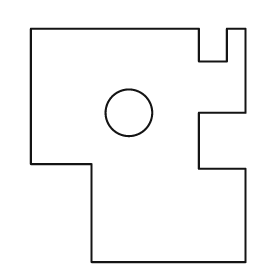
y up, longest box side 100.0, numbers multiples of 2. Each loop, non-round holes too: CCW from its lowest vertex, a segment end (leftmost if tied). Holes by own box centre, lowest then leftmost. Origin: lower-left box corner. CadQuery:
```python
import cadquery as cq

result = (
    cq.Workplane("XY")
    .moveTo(26.0, 0.0)
    .lineTo(92.0, 0.0)
    .lineTo(92.0, 40.0)
    .lineTo(72.0, 40.0)
    .lineTo(72.0, 64.0)
    .lineTo(92.0, 64.0)
    .lineTo(92.0, 100.0)
    .lineTo(84.0, 100.0)
    .lineTo(84.0, 86.0)
    .lineTo(72.0, 86.0)
    .lineTo(72.0, 100.0)
    .lineTo(0.0, 100.0)
    .lineTo(0.0, 42.0)
    .lineTo(26.0, 42.0)
    .close()
    .moveTo(42.0, 64.0)
    .circle(10.0)
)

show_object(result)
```